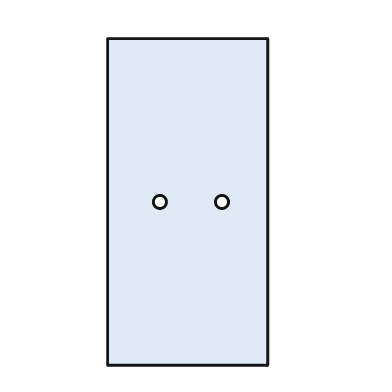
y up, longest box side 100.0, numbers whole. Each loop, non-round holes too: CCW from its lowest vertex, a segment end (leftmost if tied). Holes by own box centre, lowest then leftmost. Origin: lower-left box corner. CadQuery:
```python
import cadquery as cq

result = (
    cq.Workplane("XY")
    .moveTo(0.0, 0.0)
    .lineTo(49.0, 0.0)
    .lineTo(49.0, 100.0)
    .lineTo(0.0, 100.0)
    .close()
    .moveTo(16.0, 50.0)
    .circle(2.0)
    .moveTo(35.0, 50.0)
    .circle(2.0)
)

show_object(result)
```